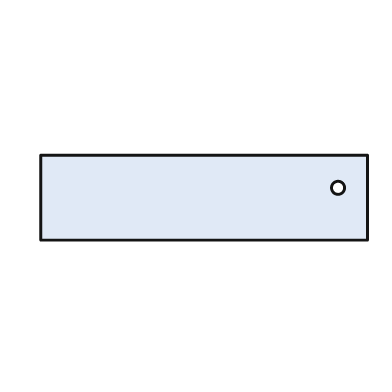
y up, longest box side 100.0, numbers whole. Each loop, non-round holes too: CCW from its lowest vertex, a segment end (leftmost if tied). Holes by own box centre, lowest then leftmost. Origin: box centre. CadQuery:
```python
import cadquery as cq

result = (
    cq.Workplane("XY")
    .moveTo(-50.0, -13.0)
    .lineTo(50.0, -13.0)
    .lineTo(50.0, 13.0)
    .lineTo(-50.0, 13.0)
    .close()
    .moveTo(41.0, 3.0)
    .circle(2.0)
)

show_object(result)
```